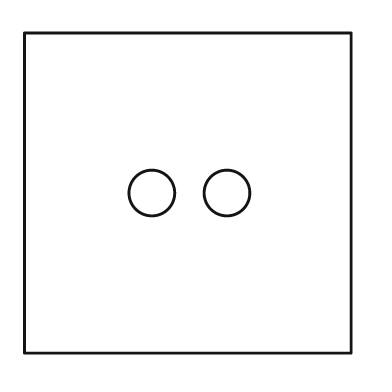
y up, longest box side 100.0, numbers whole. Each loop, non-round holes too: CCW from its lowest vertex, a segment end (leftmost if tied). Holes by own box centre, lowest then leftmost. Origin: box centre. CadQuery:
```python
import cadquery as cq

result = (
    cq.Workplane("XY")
    .moveTo(-50.0, -49.0)
    .lineTo(50.0, -49.0)
    .lineTo(50.0, 49.0)
    .lineTo(-50.0, 49.0)
    .close()
    .moveTo(-11.0, 0.0)
    .circle(7.0)
    .moveTo(12.0, 0.0)
    .circle(7.0)
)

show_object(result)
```